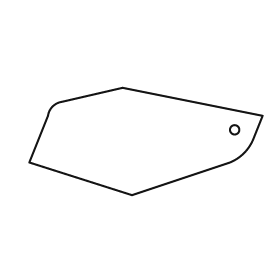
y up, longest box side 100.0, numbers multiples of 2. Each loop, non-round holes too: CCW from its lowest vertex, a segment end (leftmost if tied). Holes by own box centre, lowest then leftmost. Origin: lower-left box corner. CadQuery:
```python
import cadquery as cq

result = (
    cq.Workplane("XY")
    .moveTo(44.0, 0.0)
    .lineTo(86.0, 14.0)
    .threePointArc((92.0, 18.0), (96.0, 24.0))
    .lineTo(100.0, 34.0)
    .lineTo(40.0, 46.0)
    .lineTo(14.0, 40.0)
    .threePointArc((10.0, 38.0), (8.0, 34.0))
    .lineTo(0.0, 14.0)
    .close()
    .moveTo(88.0, 28.0)
    .circle(2.0)
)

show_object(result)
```